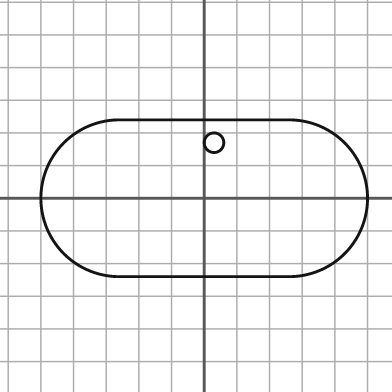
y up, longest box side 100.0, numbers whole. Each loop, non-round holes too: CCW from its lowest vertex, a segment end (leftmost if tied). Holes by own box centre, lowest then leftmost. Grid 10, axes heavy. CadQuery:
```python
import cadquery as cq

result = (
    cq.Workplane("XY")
    .moveTo(-26.0, -24.0)
    .lineTo(26.0, -24.0)
    .threePointArc((50.0, 0.0), (26.0, 24.0))
    .lineTo(-26.0, 24.0)
    .threePointArc((-50.0, 0.0), (-26.0, -24.0))
    .close()
    .moveTo(3.0, 17.0)
    .circle(3.0)
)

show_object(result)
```